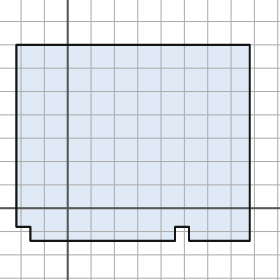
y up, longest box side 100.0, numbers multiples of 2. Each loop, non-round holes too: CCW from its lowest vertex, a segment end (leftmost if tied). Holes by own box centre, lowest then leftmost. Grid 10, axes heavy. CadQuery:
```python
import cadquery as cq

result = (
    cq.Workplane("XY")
    .moveTo(-16.0, -14.0)
    .lineTo(46.0, -14.0)
    .lineTo(46.0, -8.0)
    .lineTo(52.0, -8.0)
    .lineTo(52.0, -14.0)
    .lineTo(78.0, -14.0)
    .lineTo(78.0, 70.0)
    .lineTo(-22.0, 70.0)
    .lineTo(-22.0, -8.0)
    .lineTo(-16.0, -8.0)
    .close()
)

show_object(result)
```